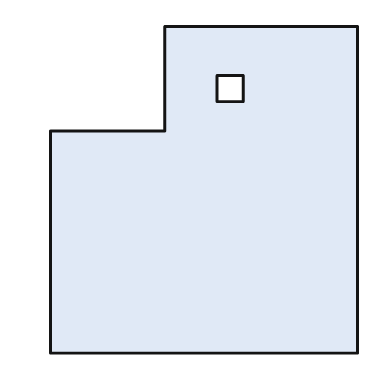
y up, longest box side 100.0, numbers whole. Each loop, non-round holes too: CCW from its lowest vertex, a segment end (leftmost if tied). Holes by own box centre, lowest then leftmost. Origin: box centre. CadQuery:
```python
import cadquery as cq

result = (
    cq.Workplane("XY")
    .moveTo(-47.0, -50.0)
    .lineTo(47.0, -50.0)
    .lineTo(47.0, 50.0)
    .lineTo(-12.0, 50.0)
    .lineTo(-12.0, 18.0)
    .lineTo(-47.0, 18.0)
    .close()
    .moveTo(4.0, 27.0)
    .lineTo(12.0, 27.0)
    .lineTo(12.0, 35.0)
    .lineTo(4.0, 35.0)
    .close()
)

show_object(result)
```